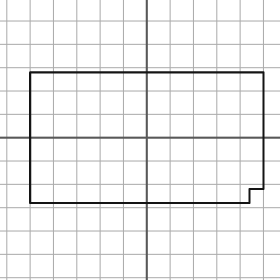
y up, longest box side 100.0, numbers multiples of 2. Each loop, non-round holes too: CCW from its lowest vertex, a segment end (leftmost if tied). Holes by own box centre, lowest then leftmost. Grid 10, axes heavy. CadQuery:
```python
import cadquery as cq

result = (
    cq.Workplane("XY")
    .moveTo(-50.0, -28.0)
    .lineTo(44.0, -28.0)
    .lineTo(44.0, -22.0)
    .lineTo(50.0, -22.0)
    .lineTo(50.0, 28.0)
    .lineTo(-50.0, 28.0)
    .close()
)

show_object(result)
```